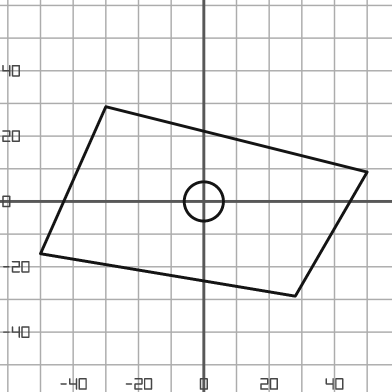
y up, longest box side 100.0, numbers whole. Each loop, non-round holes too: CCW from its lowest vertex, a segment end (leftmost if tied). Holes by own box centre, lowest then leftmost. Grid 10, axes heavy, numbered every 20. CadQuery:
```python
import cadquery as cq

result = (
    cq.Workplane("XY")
    .moveTo(28.0, -29.0)
    .lineTo(50.0, 9.0)
    .lineTo(-30.0, 29.0)
    .lineTo(-50.0, -16.0)
    .close()
    .moveTo(0.0, 0.0)
    .circle(6.0)
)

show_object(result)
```